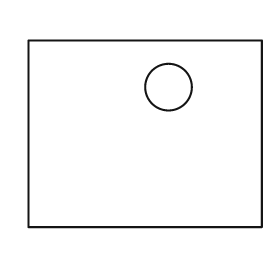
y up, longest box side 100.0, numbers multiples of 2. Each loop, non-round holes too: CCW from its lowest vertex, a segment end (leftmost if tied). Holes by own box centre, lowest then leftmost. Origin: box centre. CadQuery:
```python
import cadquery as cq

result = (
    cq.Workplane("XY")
    .moveTo(-50.0, -40.0)
    .lineTo(50.0, -40.0)
    .lineTo(50.0, 40.0)
    .lineTo(-50.0, 40.0)
    .close()
    .moveTo(10.0, 20.0)
    .circle(10.0)
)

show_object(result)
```